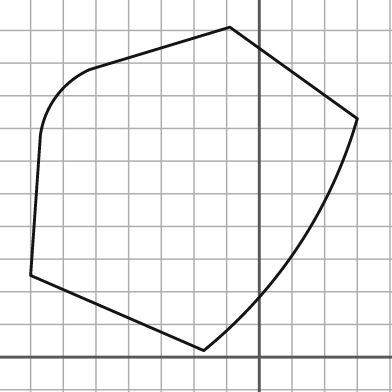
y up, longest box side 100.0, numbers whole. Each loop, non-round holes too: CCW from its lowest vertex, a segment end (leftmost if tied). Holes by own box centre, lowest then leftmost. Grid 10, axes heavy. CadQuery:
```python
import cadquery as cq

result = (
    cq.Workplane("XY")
    .moveTo(-17.0, 2.0)
    .threePointArc((12.0, 34.0), (30.0, 73.0))
    .lineTo(-9.0, 101.0)
    .lineTo(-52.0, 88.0)
    .threePointArc((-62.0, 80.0), (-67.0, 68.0))
    .lineTo(-70.0, 25.0)
    .close()
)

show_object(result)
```